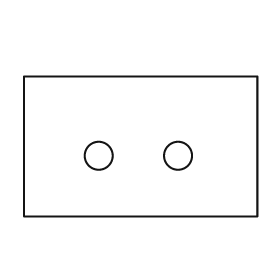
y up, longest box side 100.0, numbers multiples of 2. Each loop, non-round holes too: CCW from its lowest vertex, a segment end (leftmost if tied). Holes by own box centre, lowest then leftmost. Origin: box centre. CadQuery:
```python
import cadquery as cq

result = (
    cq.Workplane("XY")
    .moveTo(-50.0, -30.0)
    .lineTo(50.0, -30.0)
    .lineTo(50.0, 30.0)
    .lineTo(-50.0, 30.0)
    .close()
    .moveTo(-18.0, -4.0)
    .circle(6.0)
    .moveTo(16.0, -4.0)
    .circle(6.0)
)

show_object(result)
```